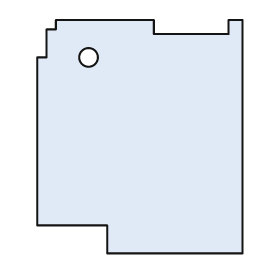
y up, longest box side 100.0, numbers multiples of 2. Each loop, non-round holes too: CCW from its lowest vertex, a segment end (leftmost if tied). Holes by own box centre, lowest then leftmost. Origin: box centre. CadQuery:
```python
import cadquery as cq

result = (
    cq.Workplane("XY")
    .moveTo(-14.0, -50.0)
    .lineTo(44.0, -50.0)
    .lineTo(44.0, 50.0)
    .lineTo(38.0, 50.0)
    .lineTo(38.0, 44.0)
    .lineTo(6.0, 44.0)
    .lineTo(6.0, 50.0)
    .lineTo(-36.0, 50.0)
    .lineTo(-36.0, 46.0)
    .lineTo(-40.0, 46.0)
    .lineTo(-40.0, 34.0)
    .lineTo(-44.0, 34.0)
    .lineTo(-44.0, -38.0)
    .lineTo(-14.0, -38.0)
    .close()
    .moveTo(-22.0, 34.0)
    .circle(4.0)
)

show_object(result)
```